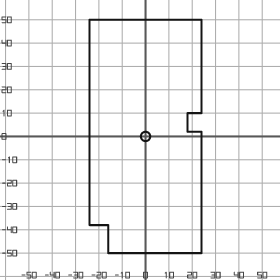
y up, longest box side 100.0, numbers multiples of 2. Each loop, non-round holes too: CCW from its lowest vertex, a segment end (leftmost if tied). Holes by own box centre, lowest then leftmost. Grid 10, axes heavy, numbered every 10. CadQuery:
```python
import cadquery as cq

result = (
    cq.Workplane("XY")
    .moveTo(-16.0, -50.0)
    .lineTo(24.0, -50.0)
    .lineTo(24.0, 2.0)
    .lineTo(18.0, 2.0)
    .lineTo(18.0, 10.0)
    .lineTo(24.0, 10.0)
    .lineTo(24.0, 50.0)
    .lineTo(-24.0, 50.0)
    .lineTo(-24.0, -38.0)
    .lineTo(-16.0, -38.0)
    .close()
    .moveTo(0.0, 0.0)
    .circle(2.0)
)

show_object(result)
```